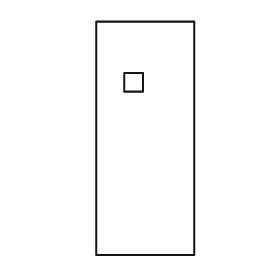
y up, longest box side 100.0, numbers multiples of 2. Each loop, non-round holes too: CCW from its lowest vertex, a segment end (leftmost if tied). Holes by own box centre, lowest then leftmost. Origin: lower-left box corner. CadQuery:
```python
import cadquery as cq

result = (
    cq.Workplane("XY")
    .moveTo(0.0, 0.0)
    .lineTo(42.0, 0.0)
    .lineTo(42.0, 100.0)
    .lineTo(0.0, 100.0)
    .close()
    .moveTo(12.0, 70.0)
    .lineTo(20.0, 70.0)
    .lineTo(20.0, 78.0)
    .lineTo(12.0, 78.0)
    .close()
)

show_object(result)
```